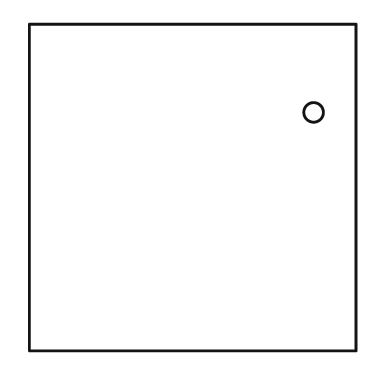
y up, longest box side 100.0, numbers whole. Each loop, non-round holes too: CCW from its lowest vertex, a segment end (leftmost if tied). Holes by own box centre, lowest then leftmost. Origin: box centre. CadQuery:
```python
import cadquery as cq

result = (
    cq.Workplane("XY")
    .moveTo(-50.0, -50.0)
    .lineTo(50.0, -50.0)
    .lineTo(50.0, 50.0)
    .lineTo(-50.0, 50.0)
    .close()
    .moveTo(37.0, 23.0)
    .circle(3.0)
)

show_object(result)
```